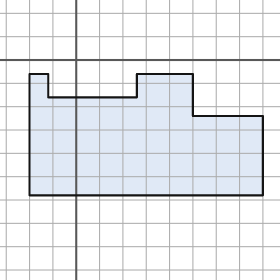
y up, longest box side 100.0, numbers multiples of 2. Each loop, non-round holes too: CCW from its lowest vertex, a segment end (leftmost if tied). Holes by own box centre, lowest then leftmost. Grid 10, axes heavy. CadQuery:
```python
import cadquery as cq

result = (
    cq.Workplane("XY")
    .moveTo(-20.0, -58.0)
    .lineTo(80.0, -58.0)
    .lineTo(80.0, -24.0)
    .lineTo(50.0, -24.0)
    .lineTo(50.0, -6.0)
    .lineTo(26.0, -6.0)
    .lineTo(26.0, -16.0)
    .lineTo(-12.0, -16.0)
    .lineTo(-12.0, -6.0)
    .lineTo(-20.0, -6.0)
    .close()
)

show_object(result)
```